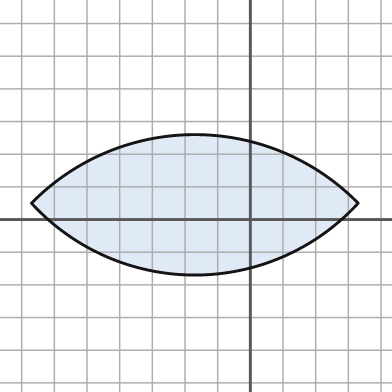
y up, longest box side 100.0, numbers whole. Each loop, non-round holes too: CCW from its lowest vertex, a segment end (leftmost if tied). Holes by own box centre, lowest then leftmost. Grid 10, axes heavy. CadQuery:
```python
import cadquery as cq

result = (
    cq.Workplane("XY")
    .moveTo(-67.0, 5.0)
    .threePointArc((-17.0, -17.0), (33.0, 5.0))
    .threePointArc((-17.0, 26.0), (-67.0, 5.0))
    .close()
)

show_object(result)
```